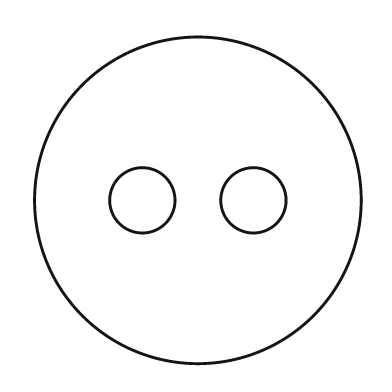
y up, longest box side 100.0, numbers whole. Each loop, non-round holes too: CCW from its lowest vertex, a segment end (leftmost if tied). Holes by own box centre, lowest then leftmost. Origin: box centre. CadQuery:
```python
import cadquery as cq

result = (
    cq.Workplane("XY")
    .moveTo(0.0, 0.0)
    .circle(50.0)
    .moveTo(-17.0, 0.0)
    .circle(10.0)
    .moveTo(17.0, 0.0)
    .circle(10.0)
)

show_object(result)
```